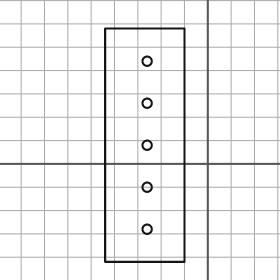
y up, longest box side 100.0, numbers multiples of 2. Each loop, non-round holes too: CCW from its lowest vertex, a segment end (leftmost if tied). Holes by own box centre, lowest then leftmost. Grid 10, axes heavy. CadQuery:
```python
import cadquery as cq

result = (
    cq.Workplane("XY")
    .moveTo(-44.0, -42.0)
    .lineTo(-10.0, -42.0)
    .lineTo(-10.0, 58.0)
    .lineTo(-44.0, 58.0)
    .close()
    .moveTo(-26.0, -28.0)
    .circle(2.0)
    .moveTo(-26.0, -10.0)
    .circle(2.0)
    .moveTo(-26.0, 8.0)
    .circle(2.0)
    .moveTo(-26.0, 26.0)
    .circle(2.0)
    .moveTo(-26.0, 44.0)
    .circle(2.0)
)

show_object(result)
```